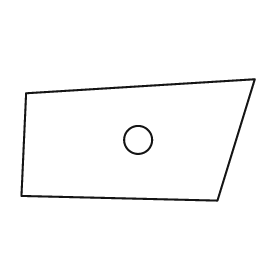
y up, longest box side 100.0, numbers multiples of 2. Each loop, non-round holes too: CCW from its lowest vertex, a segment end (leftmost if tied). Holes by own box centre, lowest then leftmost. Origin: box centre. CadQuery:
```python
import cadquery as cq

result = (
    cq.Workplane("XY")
    .moveTo(34.0, -26.0)
    .lineTo(50.0, 26.0)
    .lineTo(-48.0, 20.0)
    .lineTo(-50.0, -24.0)
    .close()
    .moveTo(0.0, 0.0)
    .circle(6.0)
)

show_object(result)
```